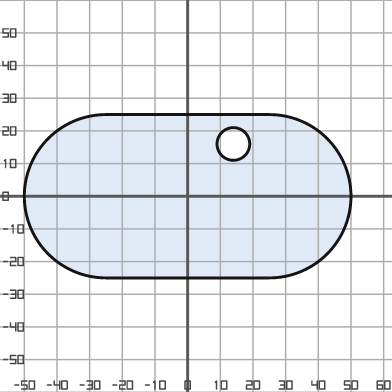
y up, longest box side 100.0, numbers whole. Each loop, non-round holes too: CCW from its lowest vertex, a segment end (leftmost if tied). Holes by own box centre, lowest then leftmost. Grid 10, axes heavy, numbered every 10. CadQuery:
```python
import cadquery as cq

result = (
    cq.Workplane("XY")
    .moveTo(-25.0, -25.0)
    .lineTo(25.0, -25.0)
    .threePointArc((50.0, 0.0), (25.0, 25.0))
    .lineTo(-25.0, 25.0)
    .threePointArc((-50.0, 0.0), (-25.0, -25.0))
    .close()
    .moveTo(14.0, 16.0)
    .circle(5.0)
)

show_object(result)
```